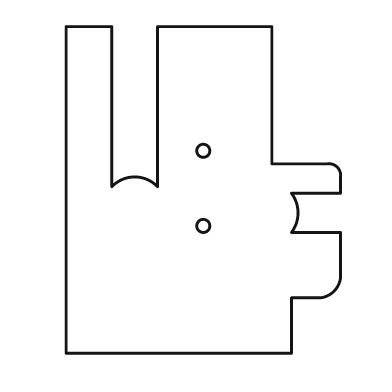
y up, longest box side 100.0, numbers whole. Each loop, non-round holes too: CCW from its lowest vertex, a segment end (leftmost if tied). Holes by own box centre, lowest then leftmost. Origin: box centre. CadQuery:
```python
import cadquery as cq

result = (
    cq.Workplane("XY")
    .moveTo(-42.0, -50.0)
    .lineTo(27.0, -50.0)
    .lineTo(27.0, -33.0)
    .lineTo(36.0, -33.0)
    .threePointArc((40.0, -31.0), (42.0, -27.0))
    .lineTo(42.0, -13.0)
    .lineTo(27.0, -13.0)
    .threePointArc((29.0, -7.0), (27.0, -1.0))
    .lineTo(42.0, -1.0)
    .lineTo(42.0, 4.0)
    .threePointArc((41.0, 7.0), (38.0, 8.0))
    .lineTo(21.0, 8.0)
    .lineTo(21.0, 50.0)
    .lineTo(-14.0, 50.0)
    .lineTo(-14.0, 1.0)
    .threePointArc((-21.0, 4.0), (-28.0, 1.0))
    .lineTo(-28.0, 50.0)
    .lineTo(-42.0, 50.0)
    .close()
    .moveTo(0.0, -11.0)
    .circle(2.0)
    .moveTo(0.0, 12.0)
    .circle(2.0)
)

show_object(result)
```